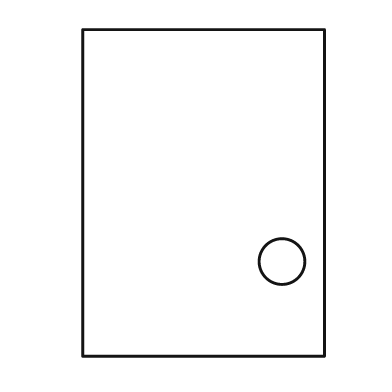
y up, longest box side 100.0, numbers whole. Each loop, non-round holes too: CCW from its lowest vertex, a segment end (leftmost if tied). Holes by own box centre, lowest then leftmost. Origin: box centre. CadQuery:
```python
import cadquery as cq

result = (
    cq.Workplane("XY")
    .moveTo(-37.0, -50.0)
    .lineTo(37.0, -50.0)
    .lineTo(37.0, 50.0)
    .lineTo(-37.0, 50.0)
    .close()
    .moveTo(24.0, -21.0)
    .circle(7.0)
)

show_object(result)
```